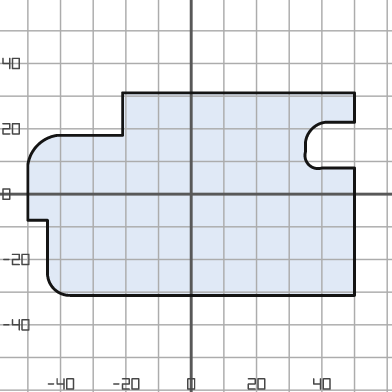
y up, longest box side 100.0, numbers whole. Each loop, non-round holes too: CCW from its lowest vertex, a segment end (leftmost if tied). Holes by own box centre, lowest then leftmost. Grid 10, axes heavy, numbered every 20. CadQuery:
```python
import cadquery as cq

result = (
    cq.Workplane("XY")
    .moveTo(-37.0, -31.0)
    .lineTo(50.0, -31.0)
    .lineTo(50.0, 8.0)
    .lineTo(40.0, 8.0)
    .threePointArc((36.0, 9.0), (35.0, 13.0))
    .lineTo(35.0, 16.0)
    .threePointArc((37.0, 20.0), (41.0, 22.0))
    .lineTo(50.0, 22.0)
    .lineTo(50.0, 31.0)
    .lineTo(-21.0, 31.0)
    .lineTo(-21.0, 18.0)
    .lineTo(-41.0, 18.0)
    .threePointArc((-47.0, 15.0), (-50.0, 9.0))
    .lineTo(-50.0, -8.0)
    .lineTo(-44.0, -8.0)
    .lineTo(-44.0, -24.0)
    .threePointArc((-42.0, -29.0), (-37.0, -31.0))
    .close()
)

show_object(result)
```